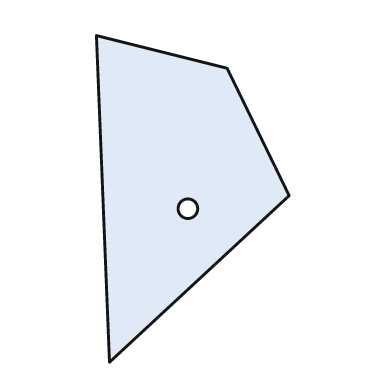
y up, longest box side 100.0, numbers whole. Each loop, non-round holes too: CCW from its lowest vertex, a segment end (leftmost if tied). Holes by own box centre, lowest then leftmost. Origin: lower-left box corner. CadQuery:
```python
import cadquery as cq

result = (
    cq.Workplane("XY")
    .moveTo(4.0, 0.0)
    .lineTo(59.0, 51.0)
    .lineTo(40.0, 90.0)
    .lineTo(0.0, 100.0)
    .close()
    .moveTo(28.0, 47.0)
    .circle(3.0)
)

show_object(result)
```